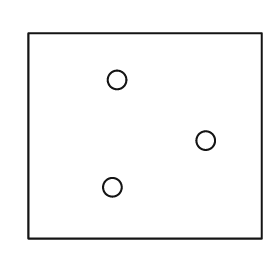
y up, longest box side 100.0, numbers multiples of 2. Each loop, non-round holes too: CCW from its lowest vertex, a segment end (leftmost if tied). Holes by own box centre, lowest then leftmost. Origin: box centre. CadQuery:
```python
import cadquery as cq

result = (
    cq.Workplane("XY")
    .moveTo(-50.0, -44.0)
    .lineTo(50.0, -44.0)
    .lineTo(50.0, 44.0)
    .lineTo(-50.0, 44.0)
    .close()
    .moveTo(-14.0, -22.0)
    .circle(4.0)
    .moveTo(26.0, -2.0)
    .circle(4.0)
    .moveTo(-12.0, 24.0)
    .circle(4.0)
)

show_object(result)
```